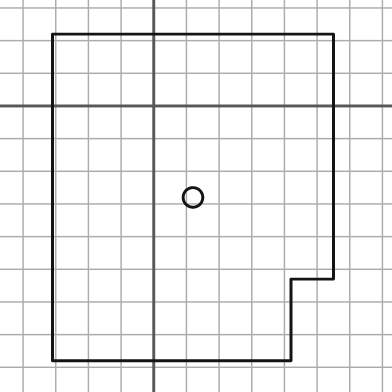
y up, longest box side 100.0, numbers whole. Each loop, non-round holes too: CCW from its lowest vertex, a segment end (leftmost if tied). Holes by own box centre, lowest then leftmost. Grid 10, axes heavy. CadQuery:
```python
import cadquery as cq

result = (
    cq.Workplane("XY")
    .moveTo(-31.0, -78.0)
    .lineTo(42.0, -78.0)
    .lineTo(42.0, -53.0)
    .lineTo(55.0, -53.0)
    .lineTo(55.0, 22.0)
    .lineTo(-31.0, 22.0)
    .close()
    .moveTo(12.0, -28.0)
    .circle(3.0)
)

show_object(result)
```